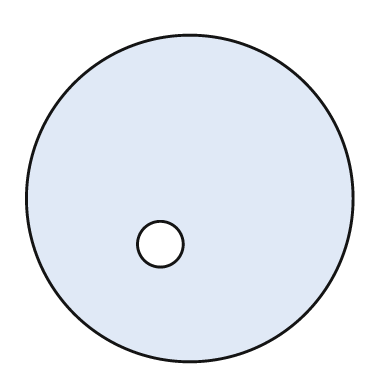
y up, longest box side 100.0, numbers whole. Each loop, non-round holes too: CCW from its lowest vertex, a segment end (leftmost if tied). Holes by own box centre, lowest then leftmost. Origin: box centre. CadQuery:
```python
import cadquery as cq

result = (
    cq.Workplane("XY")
    .moveTo(0.0, 0.0)
    .circle(50.0)
    .moveTo(-9.0, -14.0)
    .circle(7.0)
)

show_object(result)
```